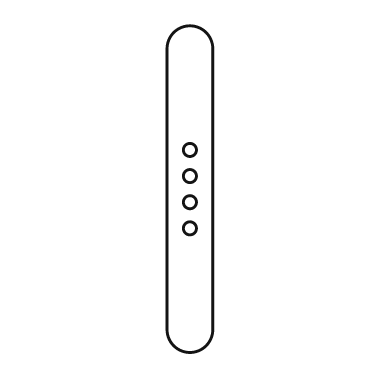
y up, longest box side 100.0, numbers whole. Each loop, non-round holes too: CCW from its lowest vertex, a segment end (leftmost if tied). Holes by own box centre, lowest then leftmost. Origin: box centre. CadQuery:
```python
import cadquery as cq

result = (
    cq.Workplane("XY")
    .moveTo(-7.0, -43.0)
    .threePointArc((0.0, -50.0), (7.0, -43.0))
    .lineTo(7.0, 43.0)
    .threePointArc((0.0, 50.0), (-7.0, 43.0))
    .close()
    .moveTo(0.0, -12.0)
    .circle(2.0)
    .moveTo(0.0, -4.0)
    .circle(2.0)
    .moveTo(0.0, 4.0)
    .circle(2.0)
    .moveTo(0.0, 12.0)
    .circle(2.0)
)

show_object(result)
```